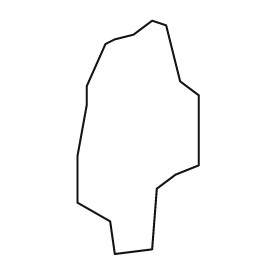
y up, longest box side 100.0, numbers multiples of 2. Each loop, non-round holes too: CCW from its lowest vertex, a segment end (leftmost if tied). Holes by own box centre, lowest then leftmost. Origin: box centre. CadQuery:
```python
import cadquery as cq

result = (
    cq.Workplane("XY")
    .moveTo(-10.0, -50.0)
    .lineTo(6.0, -48.0)
    .lineTo(8.0, -22.0)
    .lineTo(16.0, -16.0)
    .lineTo(26.0, -12.0)
    .lineTo(26.0, 18.0)
    .lineTo(18.0, 24.0)
    .lineTo(12.0, 48.0)
    .lineTo(6.0, 50.0)
    .lineTo(-2.0, 44.0)
    .lineTo(-10.0, 42.0)
    .lineTo(-14.0, 40.0)
    .lineTo(-22.0, 22.0)
    .lineTo(-22.0, 14.0)
    .lineTo(-26.0, -8.0)
    .lineTo(-26.0, -28.0)
    .lineTo(-12.0, -36.0)
    .close()
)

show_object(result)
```